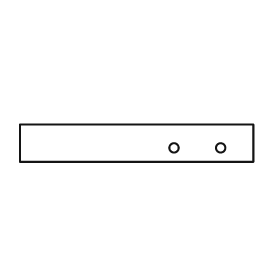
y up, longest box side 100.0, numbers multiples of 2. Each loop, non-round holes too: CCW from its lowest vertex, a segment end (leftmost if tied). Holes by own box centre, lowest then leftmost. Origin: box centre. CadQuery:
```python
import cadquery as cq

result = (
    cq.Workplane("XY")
    .moveTo(-50.0, -8.0)
    .lineTo(50.0, -8.0)
    .lineTo(50.0, 8.0)
    .lineTo(-50.0, 8.0)
    .close()
    .moveTo(16.0, -2.0)
    .circle(2.0)
    .moveTo(36.0, -2.0)
    .circle(2.0)
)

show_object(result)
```